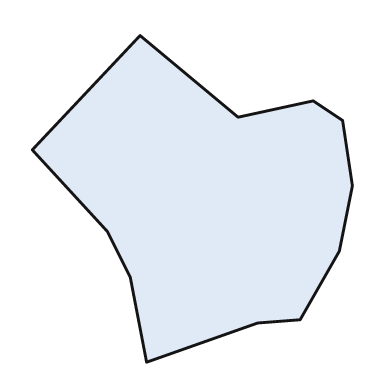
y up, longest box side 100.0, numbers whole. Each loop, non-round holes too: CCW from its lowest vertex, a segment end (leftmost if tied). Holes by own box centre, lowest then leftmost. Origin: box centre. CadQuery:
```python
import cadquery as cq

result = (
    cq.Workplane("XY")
    .moveTo(-14.0, -50.0)
    .lineTo(20.0, -38.0)
    .lineTo(33.0, -37.0)
    .lineTo(45.0, -16.0)
    .lineTo(49.0, 4.0)
    .lineTo(46.0, 24.0)
    .lineTo(37.0, 30.0)
    .lineTo(14.0, 25.0)
    .lineTo(-16.0, 50.0)
    .lineTo(-49.0, 15.0)
    .lineTo(-26.0, -10.0)
    .lineTo(-19.0, -24.0)
    .close()
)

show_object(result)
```